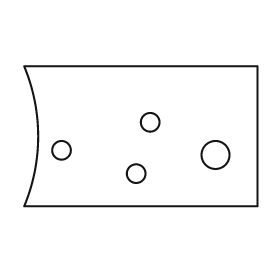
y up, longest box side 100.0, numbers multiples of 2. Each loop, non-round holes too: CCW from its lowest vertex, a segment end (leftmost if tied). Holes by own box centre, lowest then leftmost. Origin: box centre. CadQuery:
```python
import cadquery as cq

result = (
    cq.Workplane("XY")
    .moveTo(-50.0, -30.0)
    .lineTo(50.0, -30.0)
    .lineTo(50.0, 30.0)
    .lineTo(-50.0, 30.0)
    .threePointArc((-44.0, 0.0), (-50.0, -30.0))
    .close()
    .moveTo(-2.0, -16.0)
    .circle(4.0)
    .moveTo(32.0, -8.0)
    .circle(6.0)
    .moveTo(-34.0, -6.0)
    .circle(4.0)
    .moveTo(4.0, 6.0)
    .circle(4.0)
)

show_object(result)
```